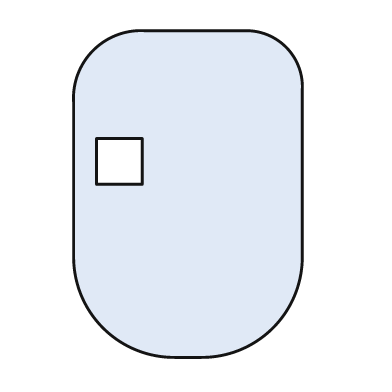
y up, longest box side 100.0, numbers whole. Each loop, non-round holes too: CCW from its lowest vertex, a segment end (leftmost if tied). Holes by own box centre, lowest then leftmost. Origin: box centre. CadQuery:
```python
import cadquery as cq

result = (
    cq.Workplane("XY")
    .moveTo(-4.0, -50.0)
    .lineTo(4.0, -50.0)
    .threePointArc((26.0, -41.0), (35.0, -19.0))
    .lineTo(35.0, 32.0)
    .threePointArc((30.0, 45.0), (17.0, 50.0))
    .lineTo(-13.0, 50.0)
    .threePointArc((-29.0, 44.0), (-35.0, 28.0))
    .lineTo(-35.0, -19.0)
    .threePointArc((-26.0, -41.0), (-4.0, -50.0))
    .close()
    .moveTo(-28.0, 3.0)
    .lineTo(-14.0, 3.0)
    .lineTo(-14.0, 17.0)
    .lineTo(-28.0, 17.0)
    .close()
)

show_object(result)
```